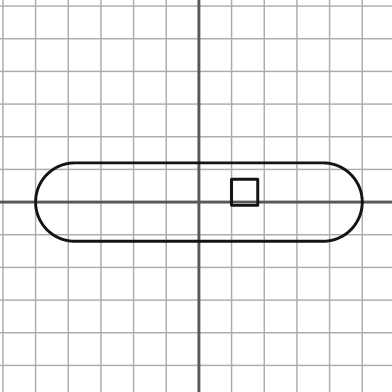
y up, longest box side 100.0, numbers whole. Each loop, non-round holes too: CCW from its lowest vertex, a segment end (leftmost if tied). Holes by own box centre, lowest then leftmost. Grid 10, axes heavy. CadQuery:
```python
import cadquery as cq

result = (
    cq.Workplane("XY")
    .moveTo(-38.0, -12.0)
    .lineTo(38.0, -12.0)
    .threePointArc((50.0, 0.0), (38.0, 12.0))
    .lineTo(-38.0, 12.0)
    .threePointArc((-50.0, 0.0), (-38.0, -12.0))
    .close()
    .moveTo(10.0, -1.0)
    .lineTo(18.0, -1.0)
    .lineTo(18.0, 7.0)
    .lineTo(10.0, 7.0)
    .close()
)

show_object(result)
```